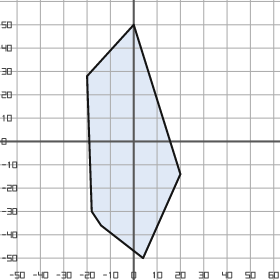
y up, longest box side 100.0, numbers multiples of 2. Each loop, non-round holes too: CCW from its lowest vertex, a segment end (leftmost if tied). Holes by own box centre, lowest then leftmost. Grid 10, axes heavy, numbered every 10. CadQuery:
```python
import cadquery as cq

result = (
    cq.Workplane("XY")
    .moveTo(4.0, -50.0)
    .lineTo(20.0, -14.0)
    .lineTo(0.0, 50.0)
    .lineTo(-20.0, 28.0)
    .lineTo(-18.0, -30.0)
    .lineTo(-14.0, -36.0)
    .close()
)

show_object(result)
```